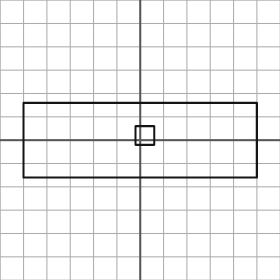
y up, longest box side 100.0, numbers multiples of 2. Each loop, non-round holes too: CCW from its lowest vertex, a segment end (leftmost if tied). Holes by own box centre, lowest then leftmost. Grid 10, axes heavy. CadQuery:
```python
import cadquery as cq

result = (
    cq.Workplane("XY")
    .moveTo(-50.0, -16.0)
    .lineTo(50.0, -16.0)
    .lineTo(50.0, 16.0)
    .lineTo(-50.0, 16.0)
    .close()
    .moveTo(-2.0, -2.0)
    .lineTo(6.0, -2.0)
    .lineTo(6.0, 6.0)
    .lineTo(-2.0, 6.0)
    .close()
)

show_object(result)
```